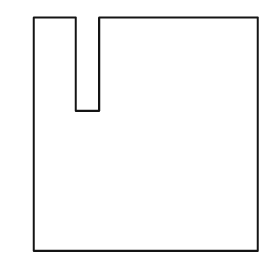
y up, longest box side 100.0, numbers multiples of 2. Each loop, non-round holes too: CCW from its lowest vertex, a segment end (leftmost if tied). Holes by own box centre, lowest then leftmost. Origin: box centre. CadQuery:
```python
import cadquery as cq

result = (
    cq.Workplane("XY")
    .moveTo(-48.0, -50.0)
    .lineTo(48.0, -50.0)
    .lineTo(48.0, 50.0)
    .lineTo(-20.0, 50.0)
    .lineTo(-20.0, 10.0)
    .lineTo(-30.0, 10.0)
    .lineTo(-30.0, 50.0)
    .lineTo(-48.0, 50.0)
    .close()
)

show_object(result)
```